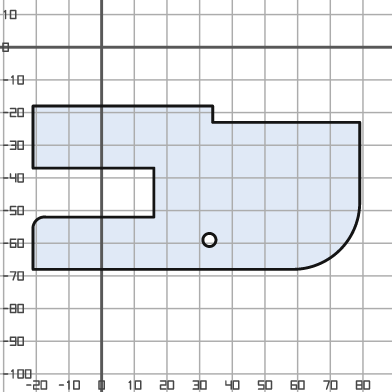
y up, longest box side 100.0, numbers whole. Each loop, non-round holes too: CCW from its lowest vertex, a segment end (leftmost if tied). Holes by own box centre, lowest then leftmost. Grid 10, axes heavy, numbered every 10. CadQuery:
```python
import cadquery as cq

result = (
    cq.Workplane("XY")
    .moveTo(-21.0, -68.0)
    .lineTo(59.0, -68.0)
    .threePointArc((73.0, -62.0), (79.0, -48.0))
    .lineTo(79.0, -23.0)
    .lineTo(34.0, -23.0)
    .lineTo(34.0, -18.0)
    .lineTo(-21.0, -18.0)
    .lineTo(-21.0, -37.0)
    .lineTo(16.0, -37.0)
    .lineTo(16.0, -52.0)
    .lineTo(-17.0, -52.0)
    .threePointArc((-20.0, -53.0), (-21.0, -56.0))
    .close()
    .moveTo(33.0, -59.0)
    .circle(2.0)
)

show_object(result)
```